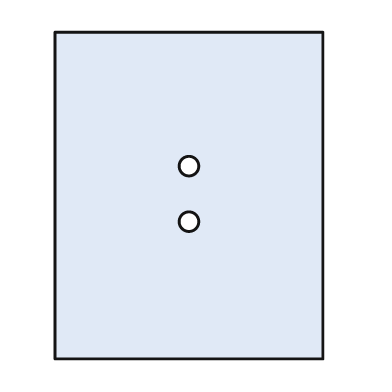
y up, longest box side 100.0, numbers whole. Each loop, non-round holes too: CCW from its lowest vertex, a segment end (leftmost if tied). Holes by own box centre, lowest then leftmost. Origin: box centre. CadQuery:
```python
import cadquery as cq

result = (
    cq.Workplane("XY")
    .moveTo(-41.0, -50.0)
    .lineTo(41.0, -50.0)
    .lineTo(41.0, 50.0)
    .lineTo(-41.0, 50.0)
    .close()
    .moveTo(0.0, -8.0)
    .circle(3.0)
    .moveTo(0.0, 9.0)
    .circle(3.0)
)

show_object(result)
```